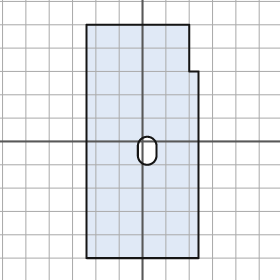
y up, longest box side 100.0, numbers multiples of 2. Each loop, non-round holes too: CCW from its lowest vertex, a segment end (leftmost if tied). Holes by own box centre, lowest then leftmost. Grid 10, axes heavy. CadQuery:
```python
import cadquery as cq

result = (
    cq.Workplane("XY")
    .moveTo(-24.0, -50.0)
    .lineTo(24.0, -50.0)
    .lineTo(24.0, 30.0)
    .lineTo(20.0, 30.0)
    .lineTo(20.0, 50.0)
    .lineTo(-24.0, 50.0)
    .close()
    .moveTo(-2.0, -6.0)
    .threePointArc((2.0, -10.0), (6.0, -6.0))
    .lineTo(6.0, -2.0)
    .threePointArc((2.0, 2.0), (-2.0, -2.0))
    .close()
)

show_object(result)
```